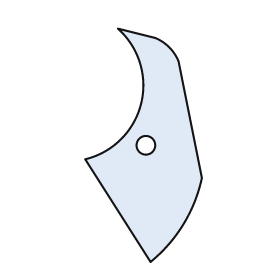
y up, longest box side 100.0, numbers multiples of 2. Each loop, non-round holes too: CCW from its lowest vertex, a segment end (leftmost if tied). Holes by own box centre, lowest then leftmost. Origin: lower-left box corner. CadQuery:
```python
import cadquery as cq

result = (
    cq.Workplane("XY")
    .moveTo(28.0, 0.0)
    .threePointArc((42.0, 16.0), (50.0, 36.0))
    .lineTo(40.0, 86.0)
    .threePointArc((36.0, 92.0), (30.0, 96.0))
    .lineTo(14.0, 100.0)
    .threePointArc((24.0, 68.0), (0.0, 44.0))
    .close()
    .moveTo(26.0, 50.0)
    .circle(4.0)
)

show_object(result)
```